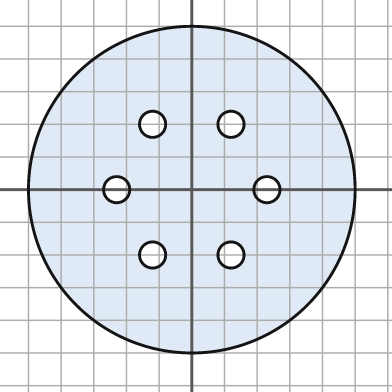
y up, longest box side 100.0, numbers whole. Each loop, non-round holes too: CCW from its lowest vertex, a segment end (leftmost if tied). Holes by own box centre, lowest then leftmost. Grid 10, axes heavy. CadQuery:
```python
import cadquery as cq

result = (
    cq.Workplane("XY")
    .moveTo(0.0, 0.0)
    .circle(50.0)
    .moveTo(-12.0, -20.0)
    .circle(4.0)
    .moveTo(12.0, -20.0)
    .circle(4.0)
    .moveTo(-23.0, 0.0)
    .circle(4.0)
    .moveTo(23.0, 0.0)
    .circle(4.0)
    .moveTo(-12.0, 20.0)
    .circle(4.0)
    .moveTo(12.0, 20.0)
    .circle(4.0)
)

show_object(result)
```